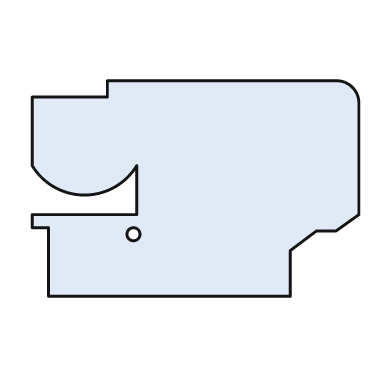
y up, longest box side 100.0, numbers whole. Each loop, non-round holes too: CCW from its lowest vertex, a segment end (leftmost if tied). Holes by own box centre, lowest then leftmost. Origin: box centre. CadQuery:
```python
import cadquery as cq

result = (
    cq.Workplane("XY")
    .moveTo(-45.0, -33.0)
    .lineTo(29.0, -33.0)
    .lineTo(29.0, -19.0)
    .lineTo(37.0, -13.0)
    .lineTo(43.0, -13.0)
    .lineTo(50.0, -8.0)
    .lineTo(50.0, 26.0)
    .threePointArc((48.0, 31.0), (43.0, 33.0))
    .lineTo(-27.0, 33.0)
    .lineTo(-27.0, 28.0)
    .lineTo(-50.0, 28.0)
    .lineTo(-50.0, 7.0)
    .threePointArc((-34.0, -2.0), (-18.0, 7.0))
    .lineTo(-18.0, -8.0)
    .lineTo(-50.0, -8.0)
    .lineTo(-50.0, -12.0)
    .lineTo(-45.0, -12.0)
    .close()
    .moveTo(-19.0, -14.0)
    .circle(2.0)
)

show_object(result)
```